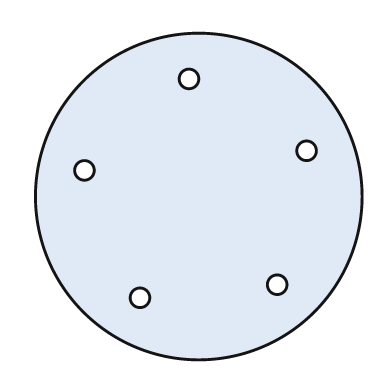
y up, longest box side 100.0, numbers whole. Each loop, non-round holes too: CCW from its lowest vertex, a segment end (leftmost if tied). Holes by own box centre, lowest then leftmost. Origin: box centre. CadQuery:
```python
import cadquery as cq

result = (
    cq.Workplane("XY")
    .moveTo(0.0, 0.0)
    .circle(50.0)
    .moveTo(-18.0, -31.0)
    .circle(3.0)
    .moveTo(24.0, -27.0)
    .circle(3.0)
    .moveTo(-35.0, 8.0)
    .circle(3.0)
    .moveTo(33.0, 14.0)
    .circle(3.0)
    .moveTo(-3.0, 36.0)
    .circle(3.0)
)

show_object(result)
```